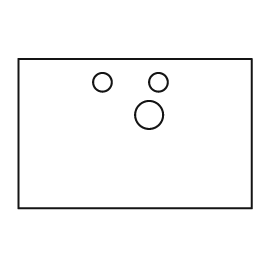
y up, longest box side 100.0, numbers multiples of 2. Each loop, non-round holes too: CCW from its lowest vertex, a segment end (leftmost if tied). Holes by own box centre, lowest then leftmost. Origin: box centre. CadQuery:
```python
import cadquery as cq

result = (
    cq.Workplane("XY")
    .moveTo(-50.0, -32.0)
    .lineTo(50.0, -32.0)
    .lineTo(50.0, 32.0)
    .lineTo(-50.0, 32.0)
    .close()
    .moveTo(6.0, 8.0)
    .circle(6.0)
    .moveTo(-14.0, 22.0)
    .circle(4.0)
    .moveTo(10.0, 22.0)
    .circle(4.0)
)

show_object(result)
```